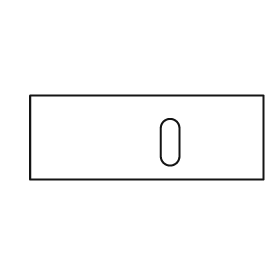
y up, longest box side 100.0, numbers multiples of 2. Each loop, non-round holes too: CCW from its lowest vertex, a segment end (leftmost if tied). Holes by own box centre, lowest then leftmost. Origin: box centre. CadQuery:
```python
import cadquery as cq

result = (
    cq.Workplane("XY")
    .moveTo(-50.0, -18.0)
    .lineTo(50.0, -18.0)
    .lineTo(50.0, 18.0)
    .lineTo(-50.0, 18.0)
    .close()
    .moveTo(6.0, -8.0)
    .threePointArc((10.0, -12.0), (14.0, -8.0))
    .lineTo(14.0, 4.0)
    .threePointArc((10.0, 8.0), (6.0, 4.0))
    .close()
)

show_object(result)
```